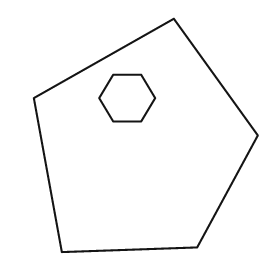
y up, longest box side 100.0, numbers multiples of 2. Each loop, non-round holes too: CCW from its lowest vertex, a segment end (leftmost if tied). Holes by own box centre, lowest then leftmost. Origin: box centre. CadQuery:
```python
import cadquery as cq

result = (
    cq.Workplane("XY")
    .moveTo(-36.0, -50.0)
    .lineTo(22.0, -48.0)
    .lineTo(48.0, 0.0)
    .lineTo(12.0, 50.0)
    .lineTo(-48.0, 16.0)
    .close()
    .moveTo(-14.0, 6.0)
    .lineTo(-2.0, 6.0)
    .lineTo(4.0, 16.0)
    .lineTo(-2.0, 26.0)
    .lineTo(-14.0, 26.0)
    .lineTo(-20.0, 16.0)
    .close()
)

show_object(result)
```